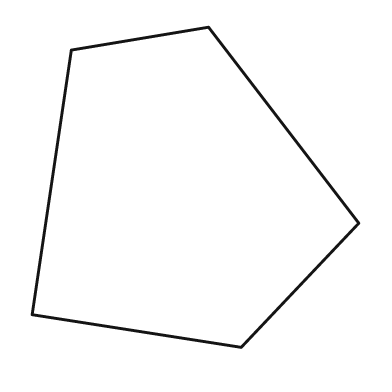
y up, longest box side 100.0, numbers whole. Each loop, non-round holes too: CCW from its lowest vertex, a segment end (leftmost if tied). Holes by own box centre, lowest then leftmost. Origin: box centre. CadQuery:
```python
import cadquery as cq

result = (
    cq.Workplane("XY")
    .moveTo(14.0, -49.0)
    .lineTo(50.0, -11.0)
    .lineTo(4.0, 49.0)
    .lineTo(-38.0, 42.0)
    .lineTo(-50.0, -39.0)
    .close()
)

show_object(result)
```